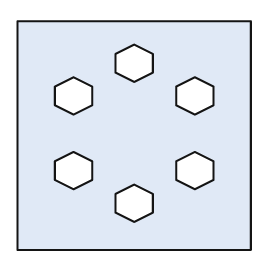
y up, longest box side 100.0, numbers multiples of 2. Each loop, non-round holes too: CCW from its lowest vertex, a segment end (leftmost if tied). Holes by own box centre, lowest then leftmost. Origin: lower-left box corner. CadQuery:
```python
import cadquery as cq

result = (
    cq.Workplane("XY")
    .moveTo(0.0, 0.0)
    .lineTo(100.0, 0.0)
    .lineTo(100.0, 98.0)
    .lineTo(0.0, 98.0)
    .close()
    .moveTo(50.0, 12.0)
    .lineTo(58.0, 16.0)
    .lineTo(58.0, 24.0)
    .lineTo(50.0, 28.0)
    .lineTo(42.0, 24.0)
    .lineTo(42.0, 16.0)
    .close()
    .moveTo(24.0, 26.0)
    .lineTo(32.0, 30.0)
    .lineTo(32.0, 38.0)
    .lineTo(24.0, 42.0)
    .lineTo(16.0, 38.0)
    .lineTo(16.0, 30.0)
    .close()
    .moveTo(76.0, 26.0)
    .lineTo(84.0, 30.0)
    .lineTo(84.0, 38.0)
    .lineTo(76.0, 42.0)
    .lineTo(68.0, 38.0)
    .lineTo(68.0, 30.0)
    .close()
    .moveTo(24.0, 58.0)
    .lineTo(32.0, 62.0)
    .lineTo(32.0, 70.0)
    .lineTo(24.0, 74.0)
    .lineTo(16.0, 70.0)
    .lineTo(16.0, 62.0)
    .close()
    .moveTo(76.0, 58.0)
    .lineTo(84.0, 62.0)
    .lineTo(84.0, 70.0)
    .lineTo(76.0, 74.0)
    .lineTo(68.0, 70.0)
    .lineTo(68.0, 62.0)
    .close()
    .moveTo(50.0, 72.0)
    .lineTo(58.0, 76.0)
    .lineTo(58.0, 84.0)
    .lineTo(50.0, 88.0)
    .lineTo(42.0, 84.0)
    .lineTo(42.0, 76.0)
    .close()
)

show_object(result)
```